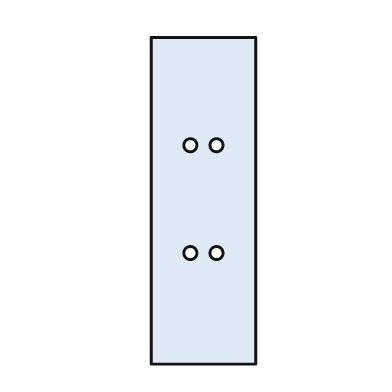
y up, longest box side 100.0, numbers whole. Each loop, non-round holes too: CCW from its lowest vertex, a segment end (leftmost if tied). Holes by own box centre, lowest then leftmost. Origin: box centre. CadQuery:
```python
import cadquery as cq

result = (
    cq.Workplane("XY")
    .moveTo(-16.0, -50.0)
    .lineTo(16.0, -50.0)
    .lineTo(16.0, 50.0)
    .lineTo(-16.0, 50.0)
    .close()
    .moveTo(-4.0, -16.0)
    .circle(2.0)
    .moveTo(4.0, -16.0)
    .circle(2.0)
    .moveTo(-4.0, 17.0)
    .circle(2.0)
    .moveTo(4.0, 17.0)
    .circle(2.0)
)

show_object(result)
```